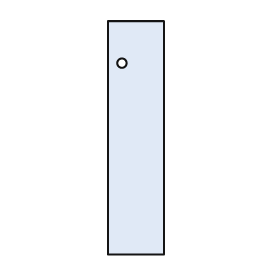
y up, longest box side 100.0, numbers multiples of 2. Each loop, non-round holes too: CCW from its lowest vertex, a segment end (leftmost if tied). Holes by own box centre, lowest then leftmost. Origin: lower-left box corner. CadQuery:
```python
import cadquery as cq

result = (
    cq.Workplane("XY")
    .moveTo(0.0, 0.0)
    .lineTo(24.0, 0.0)
    .lineTo(24.0, 100.0)
    .lineTo(0.0, 100.0)
    .close()
    .moveTo(6.0, 82.0)
    .circle(2.0)
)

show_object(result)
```